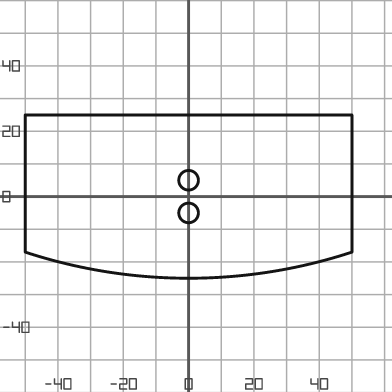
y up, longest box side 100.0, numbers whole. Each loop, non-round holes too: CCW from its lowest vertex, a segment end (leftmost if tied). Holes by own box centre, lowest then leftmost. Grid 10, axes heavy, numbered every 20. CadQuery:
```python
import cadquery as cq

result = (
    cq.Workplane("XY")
    .moveTo(-50.0, -17.0)
    .threePointArc((0.0, -25.0), (50.0, -17.0))
    .lineTo(50.0, 25.0)
    .lineTo(-50.0, 25.0)
    .close()
    .moveTo(0.0, -5.0)
    .circle(3.0)
    .moveTo(0.0, 5.0)
    .circle(3.0)
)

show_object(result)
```